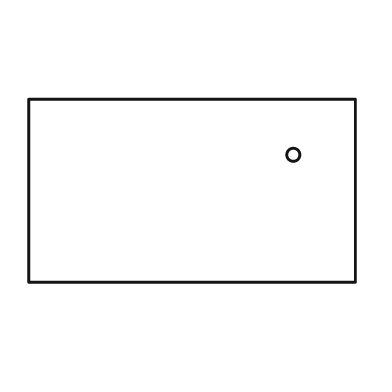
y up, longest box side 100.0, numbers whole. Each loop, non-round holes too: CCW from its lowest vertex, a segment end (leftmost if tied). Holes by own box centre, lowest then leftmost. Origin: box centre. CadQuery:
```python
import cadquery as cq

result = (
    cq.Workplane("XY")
    .moveTo(-50.0, -28.0)
    .lineTo(50.0, -28.0)
    .lineTo(50.0, 28.0)
    .lineTo(-50.0, 28.0)
    .close()
    .moveTo(31.0, 11.0)
    .circle(2.0)
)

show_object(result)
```